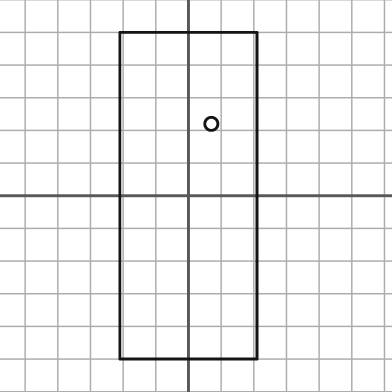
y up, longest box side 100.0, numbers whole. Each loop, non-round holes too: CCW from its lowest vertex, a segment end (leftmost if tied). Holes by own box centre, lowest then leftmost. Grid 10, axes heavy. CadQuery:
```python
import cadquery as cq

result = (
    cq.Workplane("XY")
    .moveTo(-21.0, -50.0)
    .lineTo(21.0, -50.0)
    .lineTo(21.0, 50.0)
    .lineTo(-21.0, 50.0)
    .close()
    .moveTo(7.0, 22.0)
    .circle(2.0)
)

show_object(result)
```